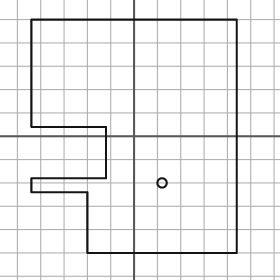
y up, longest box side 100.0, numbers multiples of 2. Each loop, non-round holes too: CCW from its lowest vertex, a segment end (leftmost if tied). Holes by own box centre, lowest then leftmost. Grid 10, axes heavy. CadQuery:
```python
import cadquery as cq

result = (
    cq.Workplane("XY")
    .moveTo(-20.0, -50.0)
    .lineTo(44.0, -50.0)
    .lineTo(44.0, 50.0)
    .lineTo(-44.0, 50.0)
    .lineTo(-44.0, 4.0)
    .lineTo(-12.0, 4.0)
    .lineTo(-12.0, -18.0)
    .lineTo(-44.0, -18.0)
    .lineTo(-44.0, -24.0)
    .lineTo(-20.0, -24.0)
    .close()
    .moveTo(12.0, -20.0)
    .circle(2.0)
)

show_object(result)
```